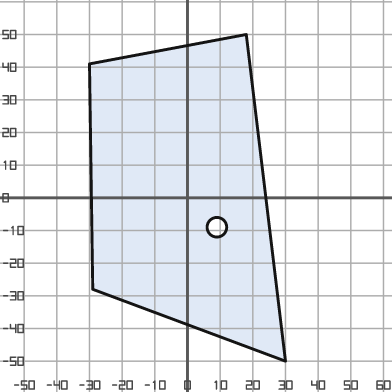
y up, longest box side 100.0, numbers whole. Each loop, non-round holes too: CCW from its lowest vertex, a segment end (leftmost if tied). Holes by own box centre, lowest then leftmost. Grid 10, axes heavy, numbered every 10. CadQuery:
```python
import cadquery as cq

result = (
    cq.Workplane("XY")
    .moveTo(30.0, -50.0)
    .lineTo(18.0, 50.0)
    .lineTo(-30.0, 41.0)
    .lineTo(-29.0, -28.0)
    .close()
    .moveTo(9.0, -9.0)
    .circle(3.0)
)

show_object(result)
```